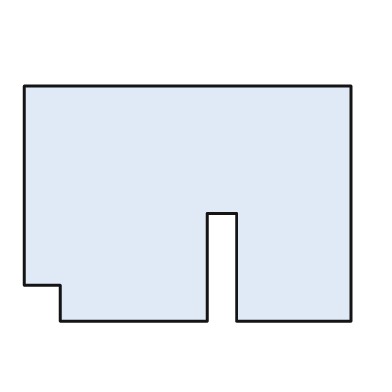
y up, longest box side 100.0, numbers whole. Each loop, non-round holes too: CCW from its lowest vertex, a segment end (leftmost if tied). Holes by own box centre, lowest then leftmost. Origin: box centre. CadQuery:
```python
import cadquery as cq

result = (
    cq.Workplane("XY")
    .moveTo(-39.0, -36.0)
    .lineTo(6.0, -36.0)
    .lineTo(6.0, -3.0)
    .lineTo(15.0, -3.0)
    .lineTo(15.0, -36.0)
    .lineTo(50.0, -36.0)
    .lineTo(50.0, 36.0)
    .lineTo(-50.0, 36.0)
    .lineTo(-50.0, -25.0)
    .lineTo(-39.0, -25.0)
    .close()
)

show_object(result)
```